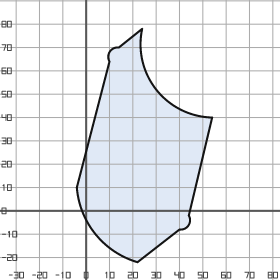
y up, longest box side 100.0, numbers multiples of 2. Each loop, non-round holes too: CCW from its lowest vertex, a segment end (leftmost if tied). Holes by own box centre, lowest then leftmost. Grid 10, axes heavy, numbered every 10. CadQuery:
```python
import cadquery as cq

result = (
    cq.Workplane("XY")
    .moveTo(22.0, -22.0)
    .lineTo(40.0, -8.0)
    .threePointArc((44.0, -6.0), (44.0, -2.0))
    .lineTo(54.0, 40.0)
    .threePointArc((30.0, 52.0), (24.0, 78.0))
    .lineTo(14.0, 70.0)
    .threePointArc((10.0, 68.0), (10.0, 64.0))
    .lineTo(-4.0, 10.0)
    .threePointArc((4.0, -10.0), (22.0, -22.0))
    .close()
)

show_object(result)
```